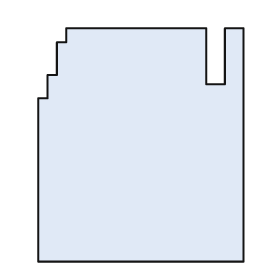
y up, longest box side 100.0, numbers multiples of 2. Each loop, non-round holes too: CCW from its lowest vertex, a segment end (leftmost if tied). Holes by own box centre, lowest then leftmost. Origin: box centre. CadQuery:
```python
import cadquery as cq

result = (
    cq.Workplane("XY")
    .moveTo(-44.0, -50.0)
    .lineTo(44.0, -50.0)
    .lineTo(44.0, 50.0)
    .lineTo(36.0, 50.0)
    .lineTo(36.0, 26.0)
    .lineTo(28.0, 26.0)
    .lineTo(28.0, 50.0)
    .lineTo(-32.0, 50.0)
    .lineTo(-32.0, 44.0)
    .lineTo(-36.0, 44.0)
    .lineTo(-36.0, 30.0)
    .lineTo(-40.0, 30.0)
    .lineTo(-40.0, 20.0)
    .lineTo(-44.0, 20.0)
    .close()
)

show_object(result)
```